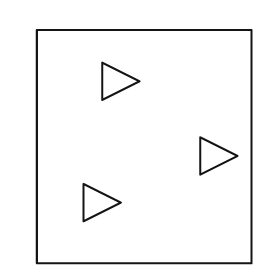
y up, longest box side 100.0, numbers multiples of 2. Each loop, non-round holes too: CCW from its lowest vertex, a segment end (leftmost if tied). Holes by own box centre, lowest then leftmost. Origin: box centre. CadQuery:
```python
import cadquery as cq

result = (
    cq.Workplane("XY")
    .moveTo(-46.0, -50.0)
    .lineTo(46.0, -50.0)
    .lineTo(46.0, 50.0)
    .lineTo(-46.0, 50.0)
    .close()
    .moveTo(-26.0, -32.0)
    .lineTo(-10.0, -24.0)
    .lineTo(-26.0, -16.0)
    .close()
    .moveTo(24.0, -12.0)
    .lineTo(40.0, -4.0)
    .lineTo(24.0, 4.0)
    .close()
    .moveTo(-18.0, 20.0)
    .lineTo(-2.0, 28.0)
    .lineTo(-18.0, 36.0)
    .close()
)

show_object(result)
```